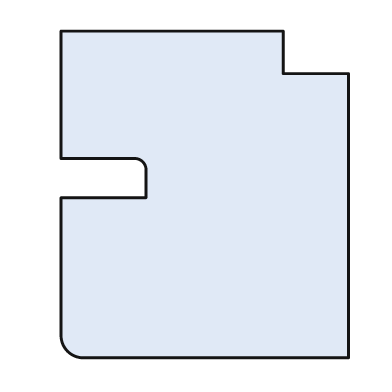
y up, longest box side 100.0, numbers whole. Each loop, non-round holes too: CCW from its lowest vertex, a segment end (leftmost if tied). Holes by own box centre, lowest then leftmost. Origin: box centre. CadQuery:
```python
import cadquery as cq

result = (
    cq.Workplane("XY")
    .moveTo(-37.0, -50.0)
    .lineTo(44.0, -50.0)
    .lineTo(44.0, 37.0)
    .lineTo(24.0, 37.0)
    .lineTo(24.0, 50.0)
    .lineTo(-44.0, 50.0)
    .lineTo(-44.0, 11.0)
    .lineTo(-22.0, 11.0)
    .threePointArc((-19.0, 10.0), (-18.0, 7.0))
    .lineTo(-18.0, -1.0)
    .lineTo(-44.0, -1.0)
    .lineTo(-44.0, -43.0)
    .threePointArc((-42.0, -48.0), (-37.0, -50.0))
    .close()
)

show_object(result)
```